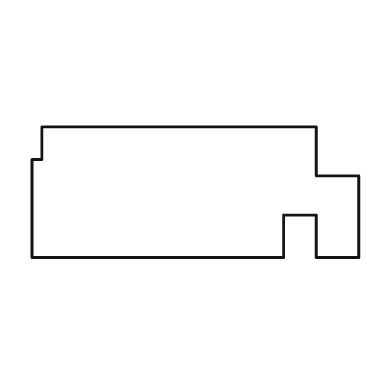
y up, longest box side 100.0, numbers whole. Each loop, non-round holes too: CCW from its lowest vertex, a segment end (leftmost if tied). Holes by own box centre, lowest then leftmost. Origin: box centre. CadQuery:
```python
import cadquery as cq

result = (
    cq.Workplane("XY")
    .moveTo(-50.0, -20.0)
    .lineTo(27.0, -20.0)
    .lineTo(27.0, -7.0)
    .lineTo(37.0, -7.0)
    .lineTo(37.0, -20.0)
    .lineTo(50.0, -20.0)
    .lineTo(50.0, 5.0)
    .lineTo(37.0, 5.0)
    .lineTo(37.0, 20.0)
    .lineTo(-47.0, 20.0)
    .lineTo(-47.0, 10.0)
    .lineTo(-50.0, 10.0)
    .close()
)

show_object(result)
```